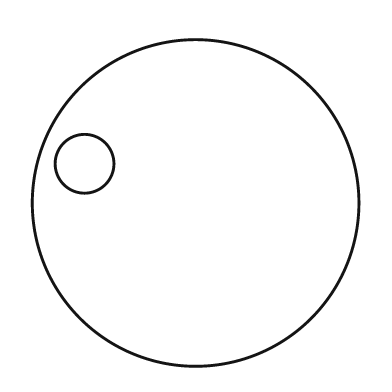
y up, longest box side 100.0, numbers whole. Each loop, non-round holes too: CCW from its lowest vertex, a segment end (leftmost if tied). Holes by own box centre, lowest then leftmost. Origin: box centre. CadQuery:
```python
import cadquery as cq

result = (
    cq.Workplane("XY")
    .moveTo(0.0, 0.0)
    .circle(50.0)
    .moveTo(-34.0, 12.0)
    .circle(9.0)
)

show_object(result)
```